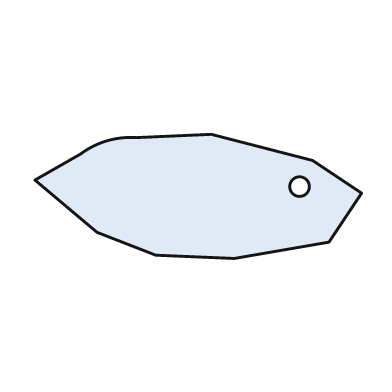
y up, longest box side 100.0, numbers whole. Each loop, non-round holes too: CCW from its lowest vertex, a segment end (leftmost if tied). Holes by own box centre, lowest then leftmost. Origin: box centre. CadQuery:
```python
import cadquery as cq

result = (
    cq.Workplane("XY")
    .moveTo(11.0, -19.0)
    .lineTo(40.0, -14.0)
    .lineTo(50.0, 1.0)
    .lineTo(35.0, 11.0)
    .lineTo(4.0, 19.0)
    .lineTo(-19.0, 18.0)
    .threePointArc((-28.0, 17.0), (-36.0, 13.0))
    .lineTo(-50.0, 5.0)
    .lineTo(-31.0, -11.0)
    .lineTo(-13.0, -18.0)
    .close()
    .moveTo(31.0, 3.0)
    .circle(3.0)
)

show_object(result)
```